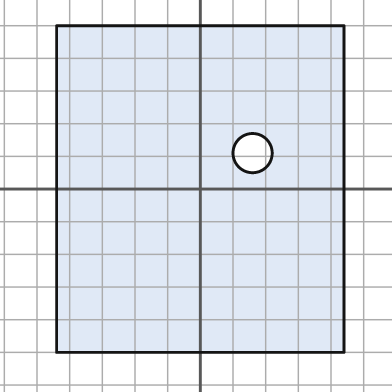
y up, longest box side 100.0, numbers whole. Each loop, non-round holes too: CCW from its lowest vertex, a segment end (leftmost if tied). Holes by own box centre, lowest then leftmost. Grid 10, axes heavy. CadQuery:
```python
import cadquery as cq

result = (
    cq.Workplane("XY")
    .moveTo(-44.0, -50.0)
    .lineTo(44.0, -50.0)
    .lineTo(44.0, 50.0)
    .lineTo(-44.0, 50.0)
    .close()
    .moveTo(16.0, 11.0)
    .circle(6.0)
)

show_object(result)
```